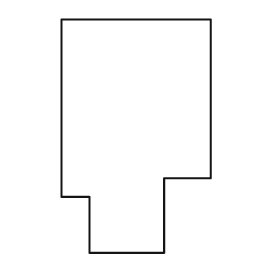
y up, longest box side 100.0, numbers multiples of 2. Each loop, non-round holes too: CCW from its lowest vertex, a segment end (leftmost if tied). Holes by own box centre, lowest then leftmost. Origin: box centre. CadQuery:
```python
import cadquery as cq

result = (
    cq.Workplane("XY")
    .moveTo(-20.0, -50.0)
    .lineTo(12.0, -50.0)
    .lineTo(12.0, -18.0)
    .lineTo(32.0, -18.0)
    .lineTo(32.0, 50.0)
    .lineTo(-32.0, 50.0)
    .lineTo(-32.0, -26.0)
    .lineTo(-20.0, -26.0)
    .close()
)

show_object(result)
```